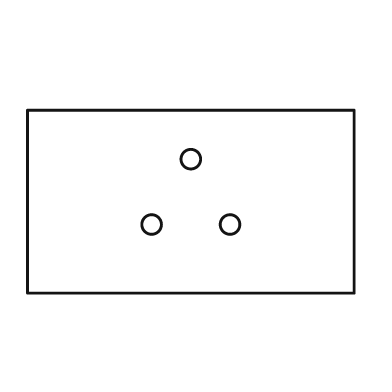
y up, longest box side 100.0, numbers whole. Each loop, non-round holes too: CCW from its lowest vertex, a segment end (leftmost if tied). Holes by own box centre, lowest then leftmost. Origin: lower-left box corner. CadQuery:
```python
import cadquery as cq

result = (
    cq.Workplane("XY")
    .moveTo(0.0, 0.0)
    .lineTo(100.0, 0.0)
    .lineTo(100.0, 56.0)
    .lineTo(0.0, 56.0)
    .close()
    .moveTo(38.0, 21.0)
    .circle(3.0)
    .moveTo(62.0, 21.0)
    .circle(3.0)
    .moveTo(50.0, 41.0)
    .circle(3.0)
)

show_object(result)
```